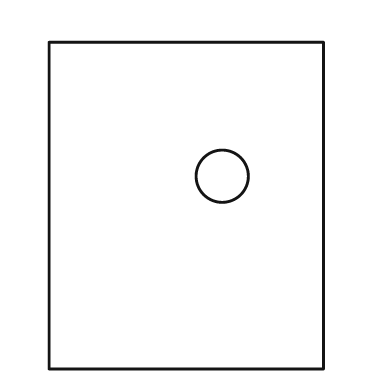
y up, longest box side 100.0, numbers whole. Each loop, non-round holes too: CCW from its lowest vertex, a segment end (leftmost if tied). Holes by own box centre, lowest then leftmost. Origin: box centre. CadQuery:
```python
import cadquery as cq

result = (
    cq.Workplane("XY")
    .moveTo(-42.0, -50.0)
    .lineTo(42.0, -50.0)
    .lineTo(42.0, 50.0)
    .lineTo(-42.0, 50.0)
    .close()
    .moveTo(11.0, 9.0)
    .circle(8.0)
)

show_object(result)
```